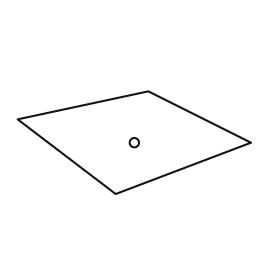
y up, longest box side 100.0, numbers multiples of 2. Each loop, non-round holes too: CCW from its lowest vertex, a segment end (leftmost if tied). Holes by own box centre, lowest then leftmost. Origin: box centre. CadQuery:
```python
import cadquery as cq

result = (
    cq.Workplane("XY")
    .moveTo(-8.0, -22.0)
    .lineTo(50.0, 0.0)
    .lineTo(6.0, 22.0)
    .lineTo(-50.0, 10.0)
    .close()
    .moveTo(0.0, 0.0)
    .circle(2.0)
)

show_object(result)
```